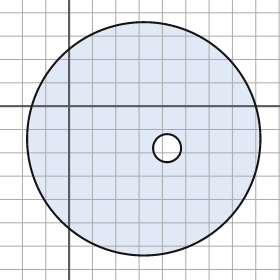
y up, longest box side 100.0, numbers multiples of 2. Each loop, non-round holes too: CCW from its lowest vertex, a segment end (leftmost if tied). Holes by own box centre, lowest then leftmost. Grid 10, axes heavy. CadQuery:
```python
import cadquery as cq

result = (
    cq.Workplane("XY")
    .moveTo(32.0, -14.0)
    .circle(50.0)
    .moveTo(42.0, -18.0)
    .circle(6.0)
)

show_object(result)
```